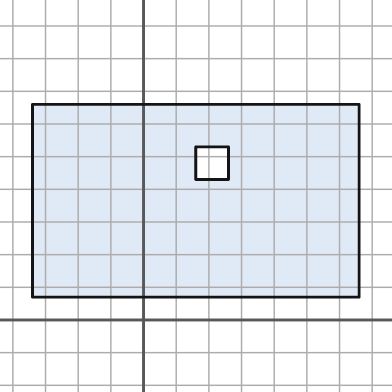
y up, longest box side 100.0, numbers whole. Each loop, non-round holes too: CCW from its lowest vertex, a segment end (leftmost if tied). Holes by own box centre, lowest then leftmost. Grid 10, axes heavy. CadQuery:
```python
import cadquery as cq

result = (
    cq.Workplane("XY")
    .moveTo(-34.0, 7.0)
    .lineTo(66.0, 7.0)
    .lineTo(66.0, 66.0)
    .lineTo(-34.0, 66.0)
    .close()
    .moveTo(16.0, 43.0)
    .lineTo(26.0, 43.0)
    .lineTo(26.0, 53.0)
    .lineTo(16.0, 53.0)
    .close()
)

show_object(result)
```